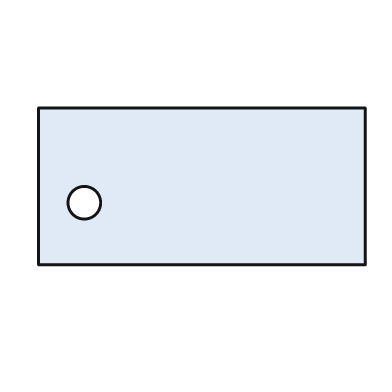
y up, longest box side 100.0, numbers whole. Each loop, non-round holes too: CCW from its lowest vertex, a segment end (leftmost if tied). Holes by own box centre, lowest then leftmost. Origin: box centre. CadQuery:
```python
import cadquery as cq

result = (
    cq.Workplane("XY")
    .moveTo(-50.0, -24.0)
    .lineTo(50.0, -24.0)
    .lineTo(50.0, 24.0)
    .lineTo(-50.0, 24.0)
    .close()
    .moveTo(-36.0, -5.0)
    .circle(5.0)
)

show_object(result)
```